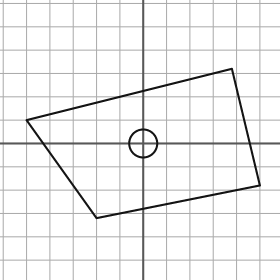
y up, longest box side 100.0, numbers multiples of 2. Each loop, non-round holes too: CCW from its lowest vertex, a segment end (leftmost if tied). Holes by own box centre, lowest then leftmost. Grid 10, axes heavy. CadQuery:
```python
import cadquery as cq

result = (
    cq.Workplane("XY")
    .moveTo(-20.0, -32.0)
    .lineTo(50.0, -18.0)
    .lineTo(38.0, 32.0)
    .lineTo(-50.0, 10.0)
    .close()
    .moveTo(0.0, 0.0)
    .circle(6.0)
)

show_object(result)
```